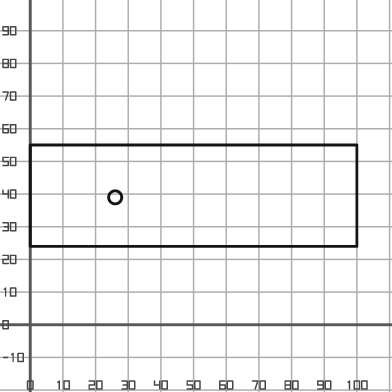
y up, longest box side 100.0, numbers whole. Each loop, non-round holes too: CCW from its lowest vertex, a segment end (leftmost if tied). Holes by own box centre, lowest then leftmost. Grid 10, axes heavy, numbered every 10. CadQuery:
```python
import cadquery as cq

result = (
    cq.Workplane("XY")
    .moveTo(0.0, 24.0)
    .lineTo(100.0, 24.0)
    .lineTo(100.0, 55.0)
    .lineTo(0.0, 55.0)
    .close()
    .moveTo(26.0, 39.0)
    .circle(2.0)
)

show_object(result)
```